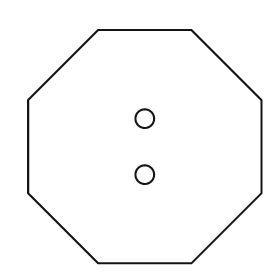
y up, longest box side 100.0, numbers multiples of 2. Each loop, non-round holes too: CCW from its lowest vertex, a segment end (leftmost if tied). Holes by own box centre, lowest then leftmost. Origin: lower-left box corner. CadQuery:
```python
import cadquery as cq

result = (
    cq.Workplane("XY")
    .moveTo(30.0, 0.0)
    .lineTo(70.0, 0.0)
    .lineTo(100.0, 30.0)
    .lineTo(100.0, 70.0)
    .lineTo(70.0, 100.0)
    .lineTo(30.0, 100.0)
    .lineTo(0.0, 70.0)
    .lineTo(0.0, 30.0)
    .close()
    .moveTo(50.0, 38.0)
    .circle(4.0)
    .moveTo(50.0, 62.0)
    .circle(4.0)
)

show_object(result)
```